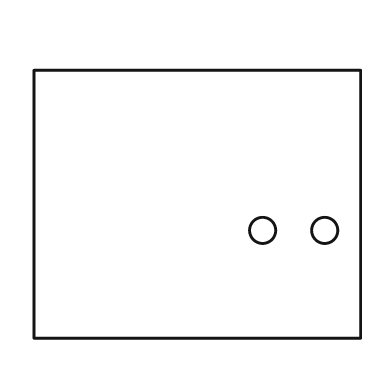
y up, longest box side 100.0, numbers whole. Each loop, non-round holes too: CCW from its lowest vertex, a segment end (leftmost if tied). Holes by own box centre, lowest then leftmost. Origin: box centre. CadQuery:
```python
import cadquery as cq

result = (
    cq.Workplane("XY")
    .moveTo(-50.0, -41.0)
    .lineTo(50.0, -41.0)
    .lineTo(50.0, 41.0)
    .lineTo(-50.0, 41.0)
    .close()
    .moveTo(20.0, -8.0)
    .circle(4.0)
    .moveTo(39.0, -8.0)
    .circle(4.0)
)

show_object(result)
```